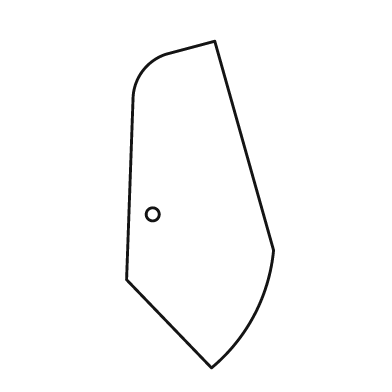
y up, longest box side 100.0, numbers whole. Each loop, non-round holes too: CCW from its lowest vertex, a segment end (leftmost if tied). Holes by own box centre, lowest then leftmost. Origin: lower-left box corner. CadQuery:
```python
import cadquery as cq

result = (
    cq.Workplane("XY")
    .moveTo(26.0, 0.0)
    .threePointArc((39.0, 16.0), (45.0, 36.0))
    .lineTo(27.0, 100.0)
    .lineTo(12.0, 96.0)
    .threePointArc((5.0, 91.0), (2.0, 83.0))
    .lineTo(0.0, 27.0)
    .close()
    .moveTo(8.0, 47.0)
    .circle(2.0)
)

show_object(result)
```